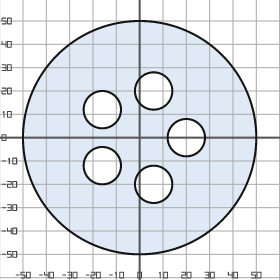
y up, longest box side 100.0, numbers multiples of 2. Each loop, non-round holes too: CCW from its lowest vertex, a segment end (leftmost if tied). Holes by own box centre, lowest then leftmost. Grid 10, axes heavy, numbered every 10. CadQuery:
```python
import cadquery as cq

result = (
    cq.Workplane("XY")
    .moveTo(0.0, 0.0)
    .circle(50.0)
    .moveTo(6.0, -20.0)
    .circle(8.0)
    .moveTo(-16.0, -12.0)
    .circle(8.0)
    .moveTo(20.0, 0.0)
    .circle(8.0)
    .moveTo(-16.0, 12.0)
    .circle(8.0)
    .moveTo(6.0, 20.0)
    .circle(8.0)
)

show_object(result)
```